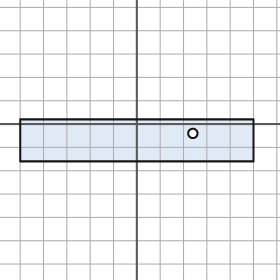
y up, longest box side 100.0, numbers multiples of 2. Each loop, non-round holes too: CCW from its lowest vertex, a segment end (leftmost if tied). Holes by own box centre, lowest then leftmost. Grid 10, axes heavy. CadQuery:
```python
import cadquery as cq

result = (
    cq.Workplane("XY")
    .moveTo(-50.0, -16.0)
    .lineTo(50.0, -16.0)
    .lineTo(50.0, 2.0)
    .lineTo(-50.0, 2.0)
    .close()
    .moveTo(24.0, -4.0)
    .circle(2.0)
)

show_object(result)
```